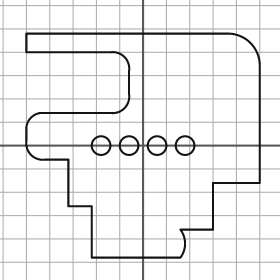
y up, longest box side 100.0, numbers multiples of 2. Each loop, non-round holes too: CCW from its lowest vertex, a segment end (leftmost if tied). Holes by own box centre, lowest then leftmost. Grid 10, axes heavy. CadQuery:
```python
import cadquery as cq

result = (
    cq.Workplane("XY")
    .moveTo(-22.0, -48.0)
    .lineTo(16.0, -48.0)
    .threePointArc((18.0, -42.0), (16.0, -36.0))
    .lineTo(30.0, -36.0)
    .lineTo(30.0, -16.0)
    .lineTo(50.0, -16.0)
    .lineTo(50.0, 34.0)
    .threePointArc((46.0, 44.0), (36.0, 48.0))
    .lineTo(-50.0, 48.0)
    .lineTo(-50.0, 40.0)
    .lineTo(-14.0, 40.0)
    .threePointArc((-8.0, 38.0), (-6.0, 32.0))
    .lineTo(-6.0, 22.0)
    .threePointArc((-8.0, 16.0), (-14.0, 14.0))
    .lineTo(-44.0, 14.0)
    .threePointArc((-48.0, 12.0), (-50.0, 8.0))
    .lineTo(-50.0, 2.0)
    .threePointArc((-48.0, -4.0), (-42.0, -6.0))
    .lineTo(-32.0, -6.0)
    .lineTo(-32.0, -26.0)
    .lineTo(-22.0, -26.0)
    .close()
    .moveTo(-18.0, 0.0)
    .circle(4.0)
    .moveTo(-6.0, 0.0)
    .circle(4.0)
    .moveTo(6.0, 0.0)
    .circle(4.0)
    .moveTo(18.0, 0.0)
    .circle(4.0)
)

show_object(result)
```